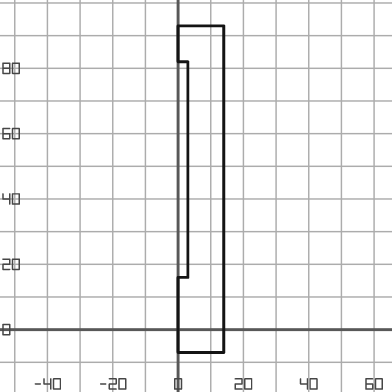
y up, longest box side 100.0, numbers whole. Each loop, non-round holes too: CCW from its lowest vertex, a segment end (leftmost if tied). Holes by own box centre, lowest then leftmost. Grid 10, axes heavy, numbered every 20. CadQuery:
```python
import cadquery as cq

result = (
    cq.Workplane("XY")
    .moveTo(0.0, -7.0)
    .lineTo(14.0, -7.0)
    .lineTo(14.0, 93.0)
    .lineTo(0.0, 93.0)
    .lineTo(0.0, 82.0)
    .lineTo(3.0, 82.0)
    .lineTo(3.0, 16.0)
    .lineTo(0.0, 16.0)
    .close()
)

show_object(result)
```